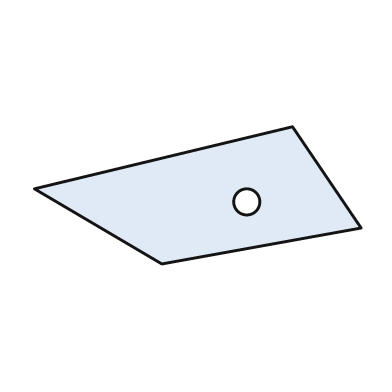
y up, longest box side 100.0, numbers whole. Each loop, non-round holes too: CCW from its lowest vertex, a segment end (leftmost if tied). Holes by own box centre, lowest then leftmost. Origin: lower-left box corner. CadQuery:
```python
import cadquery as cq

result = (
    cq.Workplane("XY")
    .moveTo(39.0, 0.0)
    .lineTo(100.0, 11.0)
    .lineTo(79.0, 42.0)
    .lineTo(0.0, 23.0)
    .close()
    .moveTo(65.0, 19.0)
    .circle(4.0)
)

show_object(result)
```